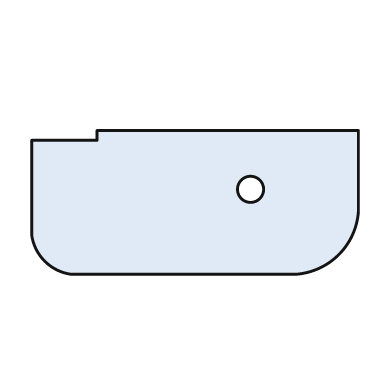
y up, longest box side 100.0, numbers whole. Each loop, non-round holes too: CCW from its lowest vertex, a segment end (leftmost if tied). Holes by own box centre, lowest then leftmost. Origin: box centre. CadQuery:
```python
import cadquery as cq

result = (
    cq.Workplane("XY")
    .moveTo(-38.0, -22.0)
    .lineTo(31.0, -22.0)
    .threePointArc((44.0, -16.0), (50.0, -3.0))
    .lineTo(50.0, 22.0)
    .lineTo(-30.0, 22.0)
    .lineTo(-30.0, 19.0)
    .lineTo(-50.0, 19.0)
    .lineTo(-50.0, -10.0)
    .threePointArc((-46.0, -18.0), (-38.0, -22.0))
    .close()
    .moveTo(17.0, 4.0)
    .circle(4.0)
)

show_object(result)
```